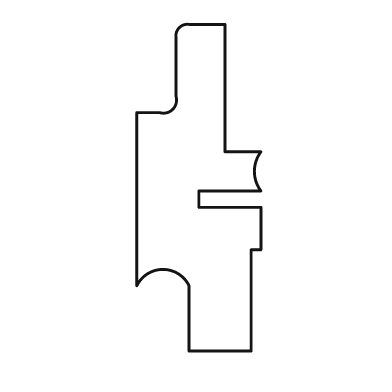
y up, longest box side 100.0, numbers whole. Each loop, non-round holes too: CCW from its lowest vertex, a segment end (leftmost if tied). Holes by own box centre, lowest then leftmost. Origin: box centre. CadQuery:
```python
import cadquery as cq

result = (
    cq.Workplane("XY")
    .moveTo(-3.0, -50.0)
    .lineTo(16.0, -50.0)
    .lineTo(16.0, -19.0)
    .lineTo(19.0, -19.0)
    .lineTo(19.0, -6.0)
    .lineTo(0.0, -6.0)
    .lineTo(0.0, -1.0)
    .lineTo(19.0, -1.0)
    .threePointArc((17.0, 5.0), (19.0, 11.0))
    .lineTo(8.0, 11.0)
    .lineTo(8.0, 50.0)
    .lineTo(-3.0, 50.0)
    .threePointArc((-6.0, 49.0), (-7.0, 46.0))
    .lineTo(-7.0, 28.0)
    .threePointArc((-8.0, 24.0), (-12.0, 23.0))
    .lineTo(-19.0, 23.0)
    .lineTo(-19.0, -30.0)
    .threePointArc((-11.0, -25.0), (-3.0, -30.0))
    .close()
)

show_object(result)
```